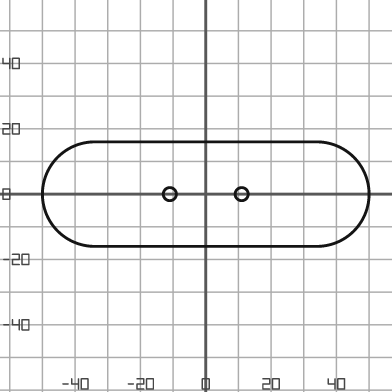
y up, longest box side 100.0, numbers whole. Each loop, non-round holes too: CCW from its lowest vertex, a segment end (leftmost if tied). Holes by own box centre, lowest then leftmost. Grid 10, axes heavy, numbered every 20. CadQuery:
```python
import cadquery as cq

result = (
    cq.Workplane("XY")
    .moveTo(-34.0, -16.0)
    .lineTo(34.0, -16.0)
    .threePointArc((50.0, 0.0), (34.0, 16.0))
    .lineTo(-34.0, 16.0)
    .threePointArc((-50.0, 0.0), (-34.0, -16.0))
    .close()
    .moveTo(-11.0, 0.0)
    .circle(2.0)
    .moveTo(11.0, 0.0)
    .circle(2.0)
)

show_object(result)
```